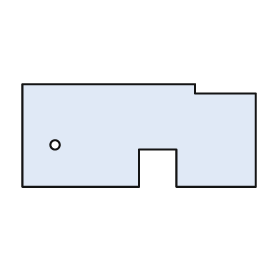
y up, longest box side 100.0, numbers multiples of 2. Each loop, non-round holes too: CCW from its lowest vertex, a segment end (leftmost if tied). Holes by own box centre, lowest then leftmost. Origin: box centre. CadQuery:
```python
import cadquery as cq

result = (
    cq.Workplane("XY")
    .moveTo(-50.0, -22.0)
    .lineTo(0.0, -22.0)
    .lineTo(0.0, -6.0)
    .lineTo(16.0, -6.0)
    .lineTo(16.0, -22.0)
    .lineTo(50.0, -22.0)
    .lineTo(50.0, 18.0)
    .lineTo(24.0, 18.0)
    .lineTo(24.0, 22.0)
    .lineTo(-50.0, 22.0)
    .close()
    .moveTo(-36.0, -4.0)
    .circle(2.0)
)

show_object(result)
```